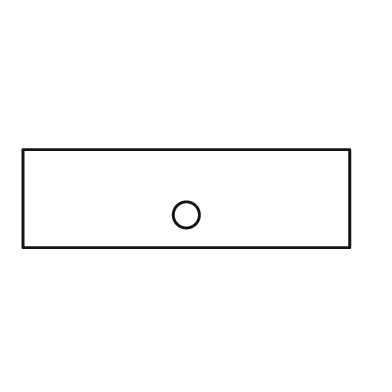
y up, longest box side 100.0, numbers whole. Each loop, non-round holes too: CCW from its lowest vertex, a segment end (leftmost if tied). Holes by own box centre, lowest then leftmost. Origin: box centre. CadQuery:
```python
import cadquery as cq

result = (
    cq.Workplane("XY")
    .moveTo(-50.0, -15.0)
    .lineTo(50.0, -15.0)
    .lineTo(50.0, 15.0)
    .lineTo(-50.0, 15.0)
    .close()
    .moveTo(0.0, -5.0)
    .circle(4.0)
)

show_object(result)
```